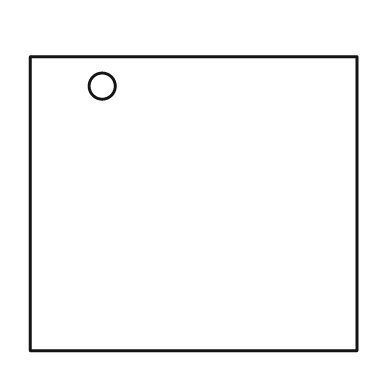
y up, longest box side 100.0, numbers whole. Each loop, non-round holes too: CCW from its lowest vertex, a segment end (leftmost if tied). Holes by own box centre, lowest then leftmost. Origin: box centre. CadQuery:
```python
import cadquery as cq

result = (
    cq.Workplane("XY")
    .moveTo(-50.0, -45.0)
    .lineTo(50.0, -45.0)
    .lineTo(50.0, 45.0)
    .lineTo(-50.0, 45.0)
    .close()
    .moveTo(-28.0, 36.0)
    .circle(4.0)
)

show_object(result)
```